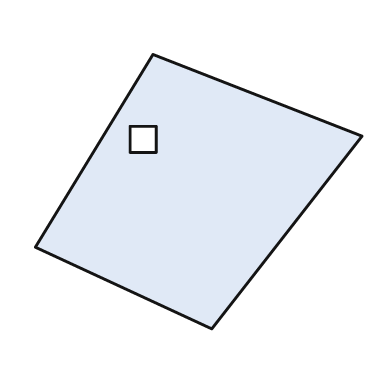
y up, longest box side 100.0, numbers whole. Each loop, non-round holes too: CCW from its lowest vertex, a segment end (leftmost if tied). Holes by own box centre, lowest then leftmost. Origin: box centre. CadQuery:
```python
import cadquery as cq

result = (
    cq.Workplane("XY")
    .moveTo(4.0, -42.0)
    .lineTo(50.0, 17.0)
    .lineTo(-14.0, 42.0)
    .lineTo(-50.0, -17.0)
    .close()
    .moveTo(-21.0, 12.0)
    .lineTo(-13.0, 12.0)
    .lineTo(-13.0, 20.0)
    .lineTo(-21.0, 20.0)
    .close()
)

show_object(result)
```